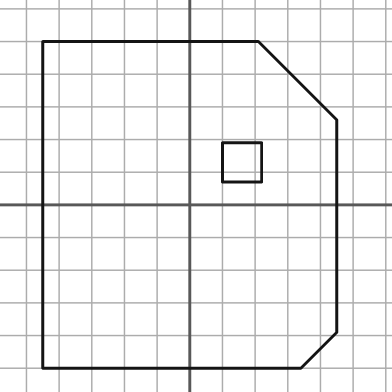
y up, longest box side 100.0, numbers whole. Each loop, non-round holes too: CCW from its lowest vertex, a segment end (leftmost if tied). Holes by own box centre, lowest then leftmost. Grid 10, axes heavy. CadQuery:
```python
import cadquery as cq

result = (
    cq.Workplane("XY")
    .moveTo(-45.0, -50.0)
    .lineTo(34.0, -50.0)
    .lineTo(45.0, -39.0)
    .lineTo(45.0, 26.0)
    .lineTo(21.0, 50.0)
    .lineTo(-45.0, 50.0)
    .close()
    .moveTo(10.0, 7.0)
    .lineTo(22.0, 7.0)
    .lineTo(22.0, 19.0)
    .lineTo(10.0, 19.0)
    .close()
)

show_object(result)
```